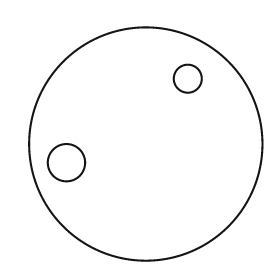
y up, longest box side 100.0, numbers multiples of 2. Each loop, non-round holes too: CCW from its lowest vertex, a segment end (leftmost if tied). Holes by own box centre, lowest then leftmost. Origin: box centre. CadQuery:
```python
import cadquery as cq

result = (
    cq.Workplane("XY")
    .moveTo(0.0, 0.0)
    .circle(50.0)
    .moveTo(-34.0, -8.0)
    .circle(8.0)
    .moveTo(18.0, 28.0)
    .circle(6.0)
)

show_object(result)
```